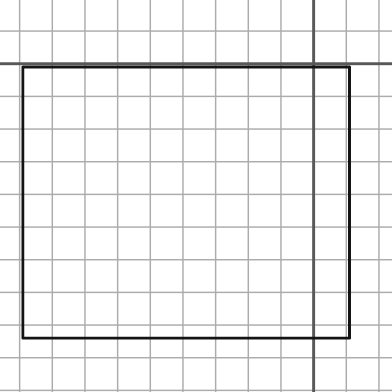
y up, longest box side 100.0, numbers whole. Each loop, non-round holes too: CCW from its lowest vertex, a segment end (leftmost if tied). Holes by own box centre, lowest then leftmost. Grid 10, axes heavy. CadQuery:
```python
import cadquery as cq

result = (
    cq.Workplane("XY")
    .moveTo(-89.0, -84.0)
    .lineTo(11.0, -84.0)
    .lineTo(11.0, -1.0)
    .lineTo(-89.0, -1.0)
    .close()
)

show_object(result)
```